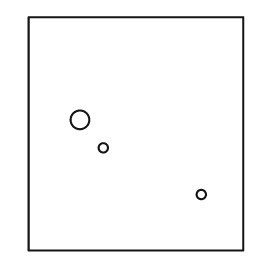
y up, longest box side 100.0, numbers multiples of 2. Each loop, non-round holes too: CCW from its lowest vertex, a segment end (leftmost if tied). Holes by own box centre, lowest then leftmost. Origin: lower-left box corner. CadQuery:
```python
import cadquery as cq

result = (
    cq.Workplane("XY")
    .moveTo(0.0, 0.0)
    .lineTo(92.0, 0.0)
    .lineTo(92.0, 100.0)
    .lineTo(0.0, 100.0)
    .close()
    .moveTo(74.0, 24.0)
    .circle(2.0)
    .moveTo(32.0, 44.0)
    .circle(2.0)
    .moveTo(22.0, 56.0)
    .circle(4.0)
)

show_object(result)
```